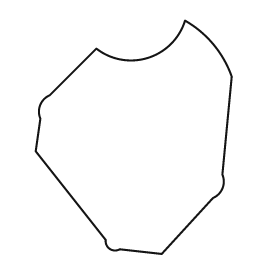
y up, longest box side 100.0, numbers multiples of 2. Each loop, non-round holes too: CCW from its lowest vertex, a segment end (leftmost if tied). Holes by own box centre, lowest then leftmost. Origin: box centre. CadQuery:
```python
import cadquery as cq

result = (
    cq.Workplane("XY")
    .moveTo(12.0, -50.0)
    .lineTo(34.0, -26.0)
    .threePointArc((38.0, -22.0), (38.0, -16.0))
    .lineTo(42.0, 26.0)
    .threePointArc((34.0, 40.0), (22.0, 50.0))
    .threePointArc((6.0, 34.0), (-16.0, 38.0))
    .lineTo(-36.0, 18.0)
    .threePointArc((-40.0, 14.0), (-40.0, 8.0))
    .lineTo(-42.0, -6.0)
    .lineTo(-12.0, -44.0)
    .threePointArc((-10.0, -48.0), (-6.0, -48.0))
    .close()
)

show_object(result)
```